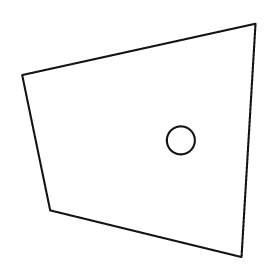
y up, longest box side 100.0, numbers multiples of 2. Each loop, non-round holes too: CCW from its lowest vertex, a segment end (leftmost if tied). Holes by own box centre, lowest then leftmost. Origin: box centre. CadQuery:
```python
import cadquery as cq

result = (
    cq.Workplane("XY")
    .moveTo(44.0, -50.0)
    .lineTo(50.0, 50.0)
    .lineTo(-50.0, 28.0)
    .lineTo(-38.0, -30.0)
    .close()
    .moveTo(18.0, 0.0)
    .circle(6.0)
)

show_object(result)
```